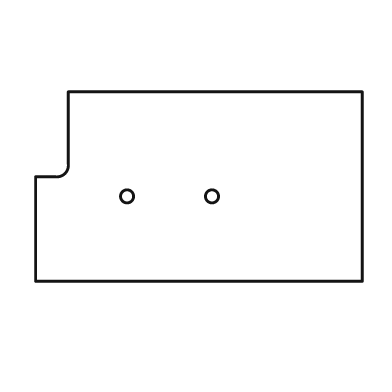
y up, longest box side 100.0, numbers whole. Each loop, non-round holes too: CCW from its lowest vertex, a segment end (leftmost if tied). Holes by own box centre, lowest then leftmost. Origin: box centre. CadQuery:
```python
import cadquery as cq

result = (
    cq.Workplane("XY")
    .moveTo(-50.0, -29.0)
    .lineTo(50.0, -29.0)
    .lineTo(50.0, 29.0)
    .lineTo(-40.0, 29.0)
    .lineTo(-40.0, 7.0)
    .threePointArc((-41.0, 4.0), (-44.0, 3.0))
    .lineTo(-50.0, 3.0)
    .close()
    .moveTo(-22.0, -3.0)
    .circle(2.0)
    .moveTo(4.0, -3.0)
    .circle(2.0)
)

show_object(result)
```